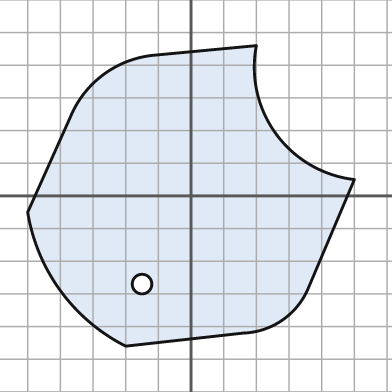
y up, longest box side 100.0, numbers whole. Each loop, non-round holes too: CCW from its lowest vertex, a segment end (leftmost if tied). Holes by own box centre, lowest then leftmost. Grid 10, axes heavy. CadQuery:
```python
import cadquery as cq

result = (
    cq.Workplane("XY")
    .moveTo(-20.0, -46.0)
    .lineTo(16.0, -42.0)
    .threePointArc((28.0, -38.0), (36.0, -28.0))
    .lineTo(50.0, 5.0)
    .threePointArc((26.0, 19.0), (20.0, 46.0))
    .lineTo(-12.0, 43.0)
    .threePointArc((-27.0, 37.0), (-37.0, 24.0))
    .lineTo(-50.0, -5.0)
    .threePointArc((-40.0, -29.0), (-20.0, -46.0))
    .close()
    .moveTo(-15.0, -27.0)
    .circle(3.0)
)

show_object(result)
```